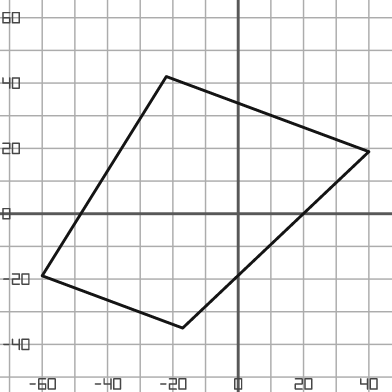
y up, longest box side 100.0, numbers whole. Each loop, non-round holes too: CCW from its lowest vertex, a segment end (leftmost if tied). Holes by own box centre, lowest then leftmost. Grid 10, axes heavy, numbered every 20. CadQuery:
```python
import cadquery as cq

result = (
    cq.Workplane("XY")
    .moveTo(-17.0, -35.0)
    .lineTo(40.0, 19.0)
    .lineTo(-22.0, 42.0)
    .lineTo(-60.0, -19.0)
    .close()
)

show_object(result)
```